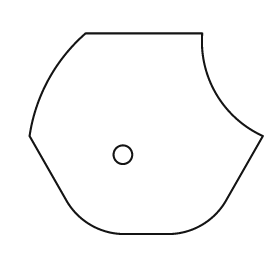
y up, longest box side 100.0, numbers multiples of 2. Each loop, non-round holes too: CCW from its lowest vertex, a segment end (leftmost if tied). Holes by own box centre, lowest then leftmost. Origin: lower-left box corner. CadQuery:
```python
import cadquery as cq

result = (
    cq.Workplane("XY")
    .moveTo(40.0, 0.0)
    .lineTo(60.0, 0.0)
    .threePointArc((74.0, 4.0), (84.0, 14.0))
    .lineTo(100.0, 42.0)
    .threePointArc((80.0, 60.0), (74.0, 86.0))
    .lineTo(24.0, 86.0)
    .threePointArc((8.0, 66.0), (0.0, 42.0))
    .lineTo(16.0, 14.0)
    .threePointArc((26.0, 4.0), (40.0, 0.0))
    .close()
    .moveTo(40.0, 34.0)
    .circle(4.0)
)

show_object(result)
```